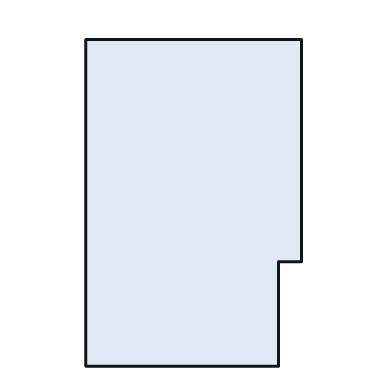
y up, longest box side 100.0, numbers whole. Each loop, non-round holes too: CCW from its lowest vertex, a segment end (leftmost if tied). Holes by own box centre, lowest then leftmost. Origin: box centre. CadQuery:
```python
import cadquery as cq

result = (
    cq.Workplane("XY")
    .moveTo(-33.0, -50.0)
    .lineTo(26.0, -50.0)
    .lineTo(26.0, -18.0)
    .lineTo(33.0, -18.0)
    .lineTo(33.0, 50.0)
    .lineTo(-33.0, 50.0)
    .close()
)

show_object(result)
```